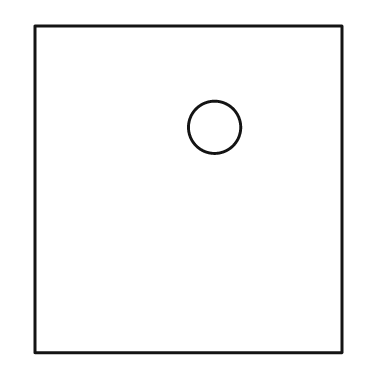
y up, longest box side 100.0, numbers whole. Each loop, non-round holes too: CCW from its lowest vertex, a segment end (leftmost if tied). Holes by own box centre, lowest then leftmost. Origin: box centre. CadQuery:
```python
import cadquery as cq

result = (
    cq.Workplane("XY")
    .moveTo(-47.0, -50.0)
    .lineTo(47.0, -50.0)
    .lineTo(47.0, 50.0)
    .lineTo(-47.0, 50.0)
    .close()
    .moveTo(8.0, 19.0)
    .circle(8.0)
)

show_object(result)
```